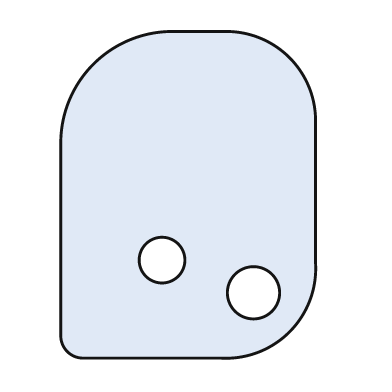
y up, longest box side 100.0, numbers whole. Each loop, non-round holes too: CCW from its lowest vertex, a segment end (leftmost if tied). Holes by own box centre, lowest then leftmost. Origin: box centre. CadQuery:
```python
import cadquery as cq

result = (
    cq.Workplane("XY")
    .moveTo(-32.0, -50.0)
    .lineTo(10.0, -50.0)
    .threePointArc((31.0, -42.0), (39.0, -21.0))
    .lineTo(39.0, 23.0)
    .threePointArc((31.0, 42.0), (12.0, 50.0))
    .lineTo(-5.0, 50.0)
    .threePointArc((-29.0, 40.0), (-39.0, 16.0))
    .lineTo(-39.0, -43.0)
    .threePointArc((-37.0, -48.0), (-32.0, -50.0))
    .close()
    .moveTo(20.0, -30.0)
    .circle(8.0)
    .moveTo(-8.0, -20.0)
    .circle(7.0)
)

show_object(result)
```